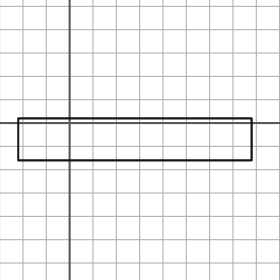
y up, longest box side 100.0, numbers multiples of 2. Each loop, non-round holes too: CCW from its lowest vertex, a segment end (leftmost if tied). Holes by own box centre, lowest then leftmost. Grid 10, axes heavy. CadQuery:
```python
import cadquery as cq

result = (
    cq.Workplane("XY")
    .moveTo(-22.0, -16.0)
    .lineTo(78.0, -16.0)
    .lineTo(78.0, 2.0)
    .lineTo(-22.0, 2.0)
    .close()
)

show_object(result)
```